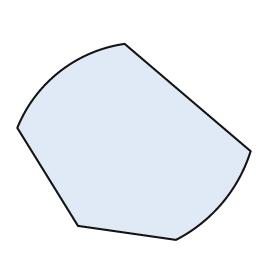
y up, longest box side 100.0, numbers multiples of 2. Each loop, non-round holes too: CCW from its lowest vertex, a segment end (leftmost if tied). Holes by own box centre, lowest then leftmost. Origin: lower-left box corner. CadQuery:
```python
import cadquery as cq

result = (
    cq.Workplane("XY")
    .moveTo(68.0, 0.0)
    .threePointArc((88.0, 16.0), (100.0, 38.0))
    .lineTo(46.0, 84.0)
    .threePointArc((18.0, 72.0), (0.0, 48.0))
    .lineTo(26.0, 6.0)
    .close()
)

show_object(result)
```